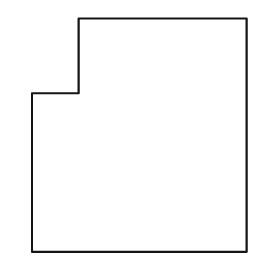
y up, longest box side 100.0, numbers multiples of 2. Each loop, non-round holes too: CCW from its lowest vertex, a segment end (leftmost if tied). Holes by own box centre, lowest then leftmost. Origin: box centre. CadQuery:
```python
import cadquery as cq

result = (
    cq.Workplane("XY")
    .moveTo(-46.0, -50.0)
    .lineTo(46.0, -50.0)
    .lineTo(46.0, 50.0)
    .lineTo(-26.0, 50.0)
    .lineTo(-26.0, 18.0)
    .lineTo(-46.0, 18.0)
    .close()
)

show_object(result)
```